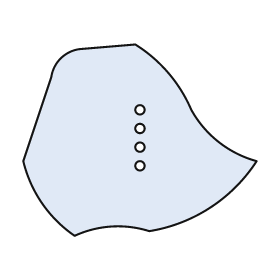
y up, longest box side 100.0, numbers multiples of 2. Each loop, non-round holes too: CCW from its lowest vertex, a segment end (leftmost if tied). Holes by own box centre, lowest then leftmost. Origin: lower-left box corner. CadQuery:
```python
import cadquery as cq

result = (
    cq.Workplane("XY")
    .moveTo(22.0, 0.0)
    .threePointArc((38.0, 4.0), (54.0, 2.0))
    .threePointArc((80.0, 12.0), (100.0, 32.0))
    .threePointArc((84.0, 40.0), (72.0, 54.0))
    .threePointArc((62.0, 70.0), (48.0, 82.0))
    .lineTo(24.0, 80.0)
    .threePointArc((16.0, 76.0), (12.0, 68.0))
    .lineTo(0.0, 32.0)
    .threePointArc((8.0, 14.0), (22.0, 0.0))
    .close()
    .moveTo(50.0, 30.0)
    .circle(2.0)
    .moveTo(50.0, 38.0)
    .circle(2.0)
    .moveTo(50.0, 46.0)
    .circle(2.0)
    .moveTo(50.0, 54.0)
    .circle(2.0)
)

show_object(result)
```